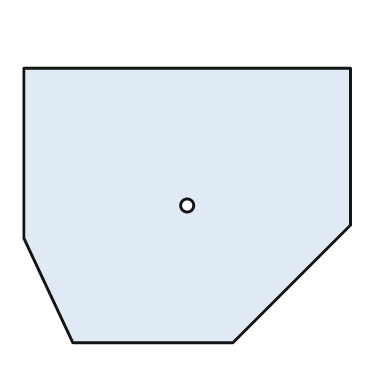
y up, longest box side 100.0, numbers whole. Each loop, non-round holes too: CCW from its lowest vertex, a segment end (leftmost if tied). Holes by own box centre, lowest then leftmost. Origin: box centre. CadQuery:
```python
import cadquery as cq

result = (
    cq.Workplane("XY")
    .moveTo(-35.0, -42.0)
    .lineTo(14.0, -42.0)
    .lineTo(50.0, -6.0)
    .lineTo(50.0, 42.0)
    .lineTo(-50.0, 42.0)
    .lineTo(-50.0, -10.0)
    .close()
    .moveTo(0.0, 0.0)
    .circle(2.0)
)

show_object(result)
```